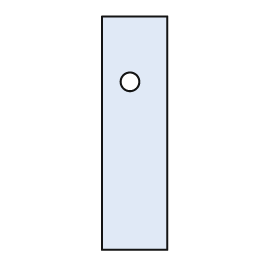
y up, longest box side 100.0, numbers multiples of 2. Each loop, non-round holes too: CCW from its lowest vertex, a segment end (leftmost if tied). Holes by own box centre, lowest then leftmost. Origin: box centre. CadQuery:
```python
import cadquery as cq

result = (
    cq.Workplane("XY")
    .moveTo(-14.0, -50.0)
    .lineTo(14.0, -50.0)
    .lineTo(14.0, 50.0)
    .lineTo(-14.0, 50.0)
    .close()
    .moveTo(-2.0, 22.0)
    .circle(4.0)
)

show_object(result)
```